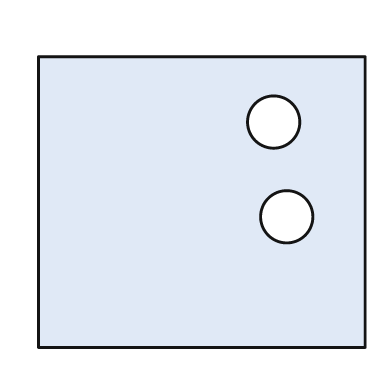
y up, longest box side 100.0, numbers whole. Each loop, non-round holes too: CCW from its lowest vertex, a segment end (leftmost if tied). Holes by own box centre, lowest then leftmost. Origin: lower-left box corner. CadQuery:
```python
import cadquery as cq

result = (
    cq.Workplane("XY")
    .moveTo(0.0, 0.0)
    .lineTo(100.0, 0.0)
    .lineTo(100.0, 89.0)
    .lineTo(0.0, 89.0)
    .close()
    .moveTo(76.0, 40.0)
    .circle(8.0)
    .moveTo(72.0, 69.0)
    .circle(8.0)
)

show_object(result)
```